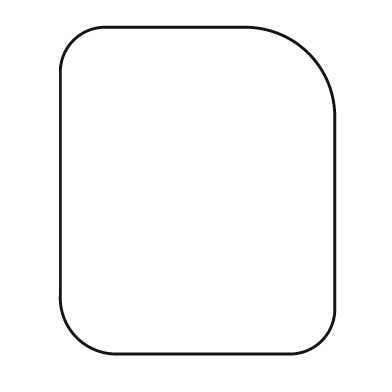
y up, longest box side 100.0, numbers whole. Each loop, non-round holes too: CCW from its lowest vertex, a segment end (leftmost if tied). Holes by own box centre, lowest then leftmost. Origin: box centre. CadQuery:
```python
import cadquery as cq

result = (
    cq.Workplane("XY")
    .moveTo(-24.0, -50.0)
    .lineTo(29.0, -50.0)
    .threePointArc((38.0, -46.0), (42.0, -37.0))
    .lineTo(42.0, 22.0)
    .threePointArc((34.0, 42.0), (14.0, 50.0))
    .lineTo(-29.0, 50.0)
    .threePointArc((-38.0, 46.0), (-42.0, 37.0))
    .lineTo(-42.0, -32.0)
    .threePointArc((-37.0, -45.0), (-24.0, -50.0))
    .close()
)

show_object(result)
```